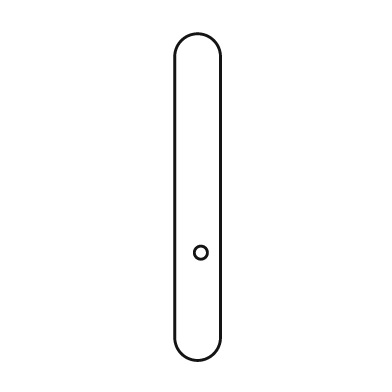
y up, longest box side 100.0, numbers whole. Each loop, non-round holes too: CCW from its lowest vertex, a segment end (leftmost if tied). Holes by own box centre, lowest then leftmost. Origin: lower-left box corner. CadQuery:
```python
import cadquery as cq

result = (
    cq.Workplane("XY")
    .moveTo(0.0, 7.0)
    .threePointArc((7.0, 0.0), (14.0, 7.0))
    .lineTo(14.0, 93.0)
    .threePointArc((7.0, 100.0), (0.0, 93.0))
    .close()
    .moveTo(8.0, 33.0)
    .circle(2.0)
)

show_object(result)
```